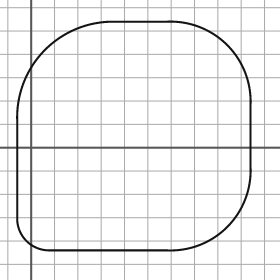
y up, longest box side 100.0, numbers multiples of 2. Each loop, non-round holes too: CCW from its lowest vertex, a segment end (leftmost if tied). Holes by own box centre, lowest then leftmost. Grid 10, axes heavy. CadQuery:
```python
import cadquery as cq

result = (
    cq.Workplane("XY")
    .moveTo(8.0, -44.0)
    .lineTo(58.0, -44.0)
    .threePointArc((84.0, -34.0), (94.0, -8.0))
    .lineTo(94.0, 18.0)
    .threePointArc((84.0, 44.0), (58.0, 54.0))
    .lineTo(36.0, 54.0)
    .threePointArc((6.0, 42.0), (-6.0, 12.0))
    .lineTo(-6.0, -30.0)
    .threePointArc((-2.0, -40.0), (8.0, -44.0))
    .close()
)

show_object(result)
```